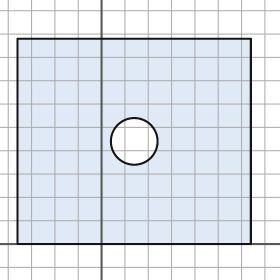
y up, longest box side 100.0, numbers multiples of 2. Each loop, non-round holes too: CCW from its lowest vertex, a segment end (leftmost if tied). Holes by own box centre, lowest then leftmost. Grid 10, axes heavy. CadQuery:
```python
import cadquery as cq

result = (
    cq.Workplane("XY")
    .moveTo(-36.0, 0.0)
    .lineTo(64.0, 0.0)
    .lineTo(64.0, 88.0)
    .lineTo(-36.0, 88.0)
    .close()
    .moveTo(14.0, 44.0)
    .circle(10.0)
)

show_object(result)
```